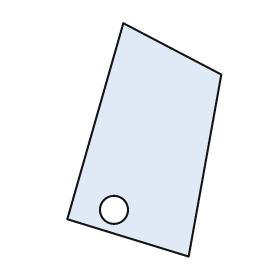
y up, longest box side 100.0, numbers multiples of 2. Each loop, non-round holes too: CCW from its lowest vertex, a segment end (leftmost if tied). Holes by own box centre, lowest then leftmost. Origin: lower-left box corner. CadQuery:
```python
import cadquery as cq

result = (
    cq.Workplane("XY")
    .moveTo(52.0, 0.0)
    .lineTo(66.0, 78.0)
    .lineTo(24.0, 100.0)
    .lineTo(0.0, 16.0)
    .close()
    .moveTo(20.0, 20.0)
    .circle(6.0)
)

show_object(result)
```